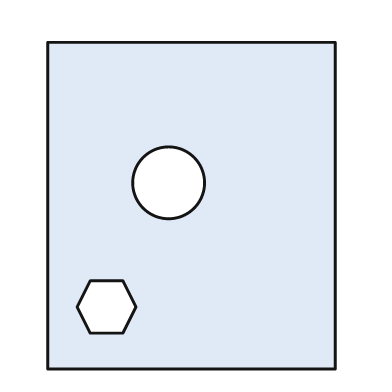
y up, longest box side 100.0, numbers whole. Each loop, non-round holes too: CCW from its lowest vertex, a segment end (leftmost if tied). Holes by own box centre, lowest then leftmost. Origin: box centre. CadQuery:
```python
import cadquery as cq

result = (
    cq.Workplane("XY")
    .moveTo(-44.0, -50.0)
    .lineTo(44.0, -50.0)
    .lineTo(44.0, 50.0)
    .lineTo(-44.0, 50.0)
    .close()
    .moveTo(-31.0, -39.0)
    .lineTo(-21.0, -39.0)
    .lineTo(-17.0, -31.0)
    .lineTo(-21.0, -23.0)
    .lineTo(-31.0, -23.0)
    .lineTo(-35.0, -31.0)
    .close()
    .moveTo(-7.0, 7.0)
    .circle(11.0)
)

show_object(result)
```